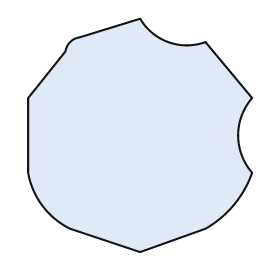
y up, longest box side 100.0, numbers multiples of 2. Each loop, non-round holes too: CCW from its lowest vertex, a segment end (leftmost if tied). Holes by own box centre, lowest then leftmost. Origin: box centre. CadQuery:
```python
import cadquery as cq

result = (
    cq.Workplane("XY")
    .moveTo(0.0, -50.0)
    .lineTo(28.0, -40.0)
    .threePointArc((40.0, -30.0), (48.0, -16.0))
    .threePointArc((42.0, 0.0), (48.0, 16.0))
    .lineTo(28.0, 40.0)
    .threePointArc((12.0, 40.0), (0.0, 50.0))
    .lineTo(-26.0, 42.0)
    .threePointArc((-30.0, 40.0), (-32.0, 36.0))
    .lineTo(-48.0, 16.0)
    .lineTo(-48.0, -16.0)
    .threePointArc((-42.0, -30.0), (-30.0, -40.0))
    .close()
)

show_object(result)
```